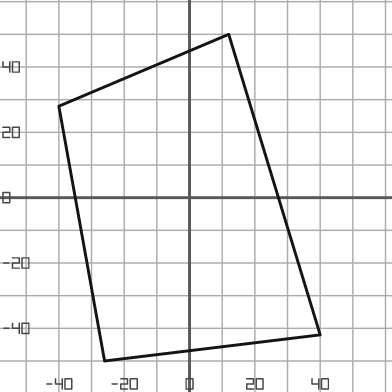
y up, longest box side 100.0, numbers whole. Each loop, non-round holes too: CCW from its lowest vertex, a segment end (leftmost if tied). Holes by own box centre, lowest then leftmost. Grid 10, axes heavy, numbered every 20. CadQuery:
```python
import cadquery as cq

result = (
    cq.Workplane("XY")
    .moveTo(-26.0, -50.0)
    .lineTo(40.0, -42.0)
    .lineTo(12.0, 50.0)
    .lineTo(-40.0, 28.0)
    .close()
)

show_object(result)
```